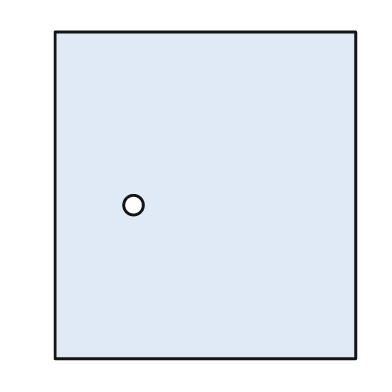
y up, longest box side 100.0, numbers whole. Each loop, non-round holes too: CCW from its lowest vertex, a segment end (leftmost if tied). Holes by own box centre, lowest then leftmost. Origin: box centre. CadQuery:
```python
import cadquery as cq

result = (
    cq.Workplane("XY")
    .moveTo(-46.0, -50.0)
    .lineTo(46.0, -50.0)
    .lineTo(46.0, 50.0)
    .lineTo(-46.0, 50.0)
    .close()
    .moveTo(-22.0, -3.0)
    .circle(3.0)
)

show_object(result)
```